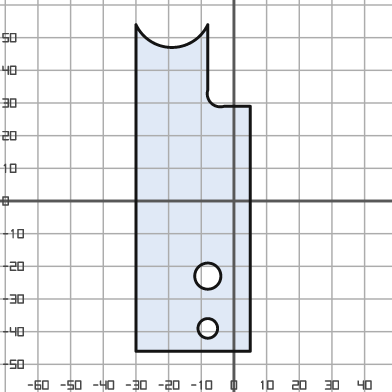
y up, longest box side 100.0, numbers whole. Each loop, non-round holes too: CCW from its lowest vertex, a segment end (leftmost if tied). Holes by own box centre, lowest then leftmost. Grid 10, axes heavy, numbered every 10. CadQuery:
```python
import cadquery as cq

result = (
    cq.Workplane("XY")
    .moveTo(-30.0, -46.0)
    .lineTo(5.0, -46.0)
    .lineTo(5.0, 29.0)
    .lineTo(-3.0, 29.0)
    .threePointArc((-7.0, 30.0), (-8.0, 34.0))
    .lineTo(-8.0, 54.0)
    .threePointArc((-19.0, 47.0), (-30.0, 54.0))
    .close()
    .moveTo(-8.0, -39.0)
    .circle(3.0)
    .moveTo(-8.0, -23.0)
    .circle(4.0)
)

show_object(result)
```